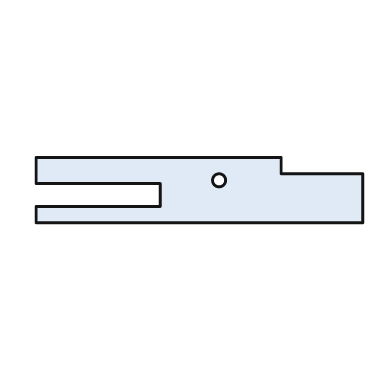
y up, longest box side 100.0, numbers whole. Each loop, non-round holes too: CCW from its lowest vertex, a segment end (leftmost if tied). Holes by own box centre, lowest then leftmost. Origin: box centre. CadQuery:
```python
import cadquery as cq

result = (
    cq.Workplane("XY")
    .moveTo(-50.0, -10.0)
    .lineTo(50.0, -10.0)
    .lineTo(50.0, 5.0)
    .lineTo(25.0, 5.0)
    .lineTo(25.0, 10.0)
    .lineTo(-50.0, 10.0)
    .lineTo(-50.0, 2.0)
    .lineTo(-12.0, 2.0)
    .lineTo(-12.0, -5.0)
    .lineTo(-50.0, -5.0)
    .close()
    .moveTo(6.0, 3.0)
    .circle(2.0)
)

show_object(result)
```